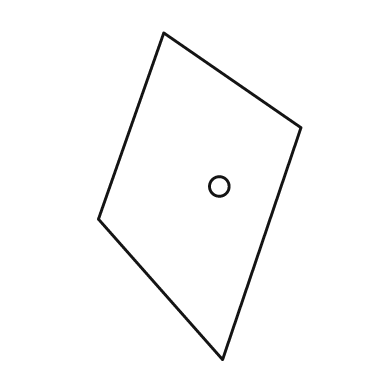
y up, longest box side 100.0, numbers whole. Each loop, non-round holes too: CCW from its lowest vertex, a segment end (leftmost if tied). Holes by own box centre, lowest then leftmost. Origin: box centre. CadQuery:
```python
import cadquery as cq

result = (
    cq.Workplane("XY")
    .moveTo(7.0, -50.0)
    .lineTo(31.0, 21.0)
    .lineTo(-11.0, 50.0)
    .lineTo(-31.0, -7.0)
    .close()
    .moveTo(6.0, 3.0)
    .circle(3.0)
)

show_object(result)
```